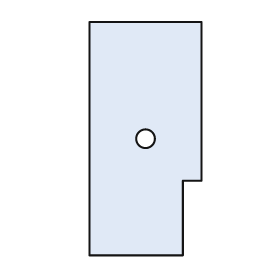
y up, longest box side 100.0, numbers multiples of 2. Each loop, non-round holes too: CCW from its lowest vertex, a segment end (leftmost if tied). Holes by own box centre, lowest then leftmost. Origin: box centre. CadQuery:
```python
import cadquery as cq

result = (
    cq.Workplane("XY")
    .moveTo(-24.0, -50.0)
    .lineTo(16.0, -50.0)
    .lineTo(16.0, -18.0)
    .lineTo(24.0, -18.0)
    .lineTo(24.0, 50.0)
    .lineTo(-24.0, 50.0)
    .close()
    .moveTo(0.0, 0.0)
    .circle(4.0)
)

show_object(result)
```